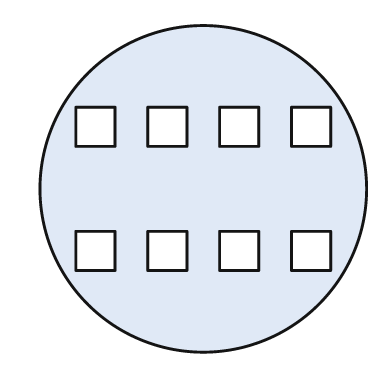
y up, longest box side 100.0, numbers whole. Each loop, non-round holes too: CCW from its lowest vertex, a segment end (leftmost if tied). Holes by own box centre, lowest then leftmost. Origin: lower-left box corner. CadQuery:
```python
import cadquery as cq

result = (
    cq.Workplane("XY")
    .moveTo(50.0, 50.0)
    .circle(50.0)
    .moveTo(11.0, 25.0)
    .lineTo(23.0, 25.0)
    .lineTo(23.0, 37.0)
    .lineTo(11.0, 37.0)
    .close()
    .moveTo(33.0, 25.0)
    .lineTo(45.0, 25.0)
    .lineTo(45.0, 37.0)
    .lineTo(33.0, 37.0)
    .close()
    .moveTo(55.0, 25.0)
    .lineTo(67.0, 25.0)
    .lineTo(67.0, 37.0)
    .lineTo(55.0, 37.0)
    .close()
    .moveTo(77.0, 25.0)
    .lineTo(89.0, 25.0)
    .lineTo(89.0, 37.0)
    .lineTo(77.0, 37.0)
    .close()
    .moveTo(11.0, 63.0)
    .lineTo(23.0, 63.0)
    .lineTo(23.0, 75.0)
    .lineTo(11.0, 75.0)
    .close()
    .moveTo(33.0, 63.0)
    .lineTo(45.0, 63.0)
    .lineTo(45.0, 75.0)
    .lineTo(33.0, 75.0)
    .close()
    .moveTo(55.0, 63.0)
    .lineTo(67.0, 63.0)
    .lineTo(67.0, 75.0)
    .lineTo(55.0, 75.0)
    .close()
    .moveTo(77.0, 63.0)
    .lineTo(89.0, 63.0)
    .lineTo(89.0, 75.0)
    .lineTo(77.0, 75.0)
    .close()
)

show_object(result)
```